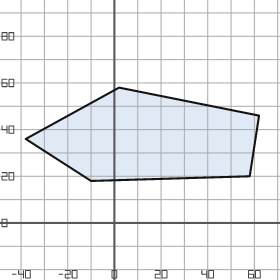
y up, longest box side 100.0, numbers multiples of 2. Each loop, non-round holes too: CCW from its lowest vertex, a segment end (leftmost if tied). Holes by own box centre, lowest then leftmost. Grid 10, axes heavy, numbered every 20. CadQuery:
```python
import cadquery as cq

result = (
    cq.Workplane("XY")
    .moveTo(-10.0, 18.0)
    .lineTo(58.0, 20.0)
    .lineTo(62.0, 46.0)
    .lineTo(2.0, 58.0)
    .lineTo(-38.0, 36.0)
    .close()
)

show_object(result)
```